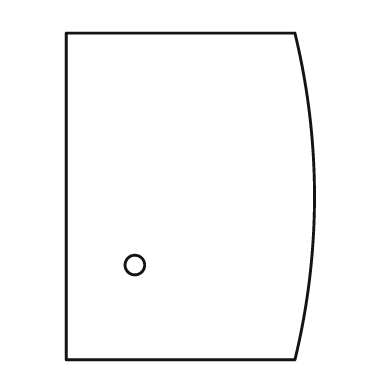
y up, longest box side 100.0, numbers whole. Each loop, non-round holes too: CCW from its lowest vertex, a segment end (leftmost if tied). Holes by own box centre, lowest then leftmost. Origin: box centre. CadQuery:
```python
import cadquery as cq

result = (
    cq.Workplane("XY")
    .moveTo(-38.0, -50.0)
    .lineTo(32.0, -50.0)
    .threePointArc((38.0, 0.0), (32.0, 50.0))
    .lineTo(-38.0, 50.0)
    .close()
    .moveTo(-17.0, -21.0)
    .circle(3.0)
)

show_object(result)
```